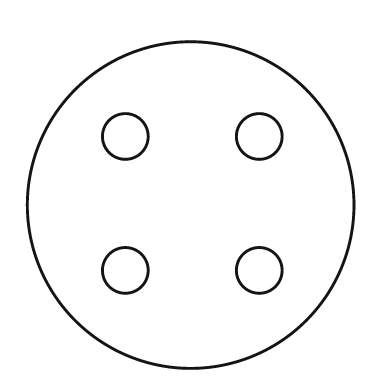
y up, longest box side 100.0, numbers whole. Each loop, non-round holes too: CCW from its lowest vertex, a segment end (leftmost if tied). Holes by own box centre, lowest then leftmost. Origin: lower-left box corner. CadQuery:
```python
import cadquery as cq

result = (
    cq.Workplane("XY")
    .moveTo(50.0, 50.0)
    .circle(50.0)
    .moveTo(30.0, 30.0)
    .circle(7.0)
    .moveTo(71.0, 30.0)
    .circle(7.0)
    .moveTo(30.0, 71.0)
    .circle(7.0)
    .moveTo(71.0, 71.0)
    .circle(7.0)
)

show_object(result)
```